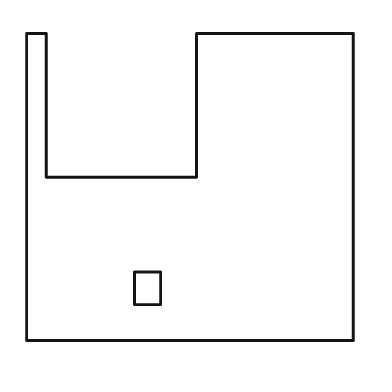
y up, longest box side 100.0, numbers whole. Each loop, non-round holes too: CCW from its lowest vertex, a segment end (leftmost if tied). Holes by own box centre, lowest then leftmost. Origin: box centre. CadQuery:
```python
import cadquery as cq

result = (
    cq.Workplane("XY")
    .moveTo(-50.0, -47.0)
    .lineTo(50.0, -47.0)
    .lineTo(50.0, 47.0)
    .lineTo(2.0, 47.0)
    .lineTo(2.0, 3.0)
    .lineTo(-44.0, 3.0)
    .lineTo(-44.0, 47.0)
    .lineTo(-50.0, 47.0)
    .close()
    .moveTo(-17.0, -36.0)
    .lineTo(-9.0, -36.0)
    .lineTo(-9.0, -26.0)
    .lineTo(-17.0, -26.0)
    .close()
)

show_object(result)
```